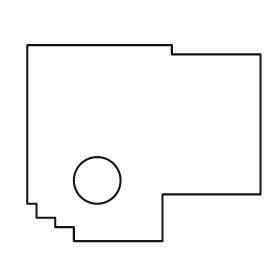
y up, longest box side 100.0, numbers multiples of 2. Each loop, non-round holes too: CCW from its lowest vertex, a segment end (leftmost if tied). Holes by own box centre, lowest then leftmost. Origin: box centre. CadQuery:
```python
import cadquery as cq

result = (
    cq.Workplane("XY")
    .moveTo(-30.0, -42.0)
    .lineTo(8.0, -42.0)
    .lineTo(8.0, -22.0)
    .lineTo(50.0, -22.0)
    .lineTo(50.0, 38.0)
    .lineTo(12.0, 38.0)
    .lineTo(12.0, 42.0)
    .lineTo(-50.0, 42.0)
    .lineTo(-50.0, -26.0)
    .lineTo(-46.0, -26.0)
    .lineTo(-46.0, -32.0)
    .lineTo(-38.0, -32.0)
    .lineTo(-38.0, -36.0)
    .lineTo(-30.0, -36.0)
    .close()
    .moveTo(-20.0, -16.0)
    .circle(10.0)
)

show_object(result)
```